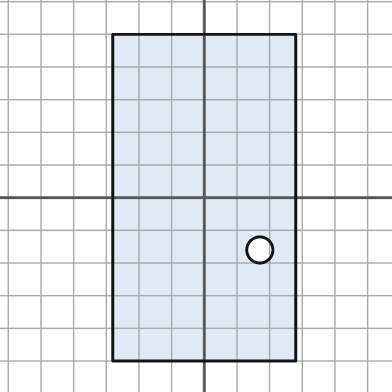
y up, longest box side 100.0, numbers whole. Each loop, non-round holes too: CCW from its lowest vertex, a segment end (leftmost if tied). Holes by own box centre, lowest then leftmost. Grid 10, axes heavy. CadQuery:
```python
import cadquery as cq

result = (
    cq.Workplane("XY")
    .moveTo(-28.0, -50.0)
    .lineTo(28.0, -50.0)
    .lineTo(28.0, 50.0)
    .lineTo(-28.0, 50.0)
    .close()
    .moveTo(17.0, -16.0)
    .circle(4.0)
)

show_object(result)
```